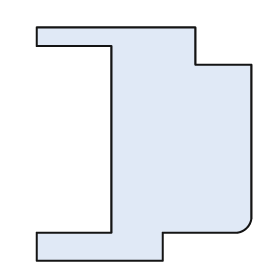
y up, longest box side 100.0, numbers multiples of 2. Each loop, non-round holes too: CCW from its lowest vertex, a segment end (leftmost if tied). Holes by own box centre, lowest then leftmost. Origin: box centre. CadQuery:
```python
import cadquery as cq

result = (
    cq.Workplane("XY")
    .moveTo(-46.0, -50.0)
    .lineTo(8.0, -50.0)
    .lineTo(8.0, -38.0)
    .lineTo(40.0, -38.0)
    .threePointArc((44.0, -36.0), (46.0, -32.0))
    .lineTo(46.0, 34.0)
    .lineTo(22.0, 34.0)
    .lineTo(22.0, 50.0)
    .lineTo(-46.0, 50.0)
    .lineTo(-46.0, 42.0)
    .lineTo(-14.0, 42.0)
    .lineTo(-14.0, -38.0)
    .lineTo(-46.0, -38.0)
    .close()
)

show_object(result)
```